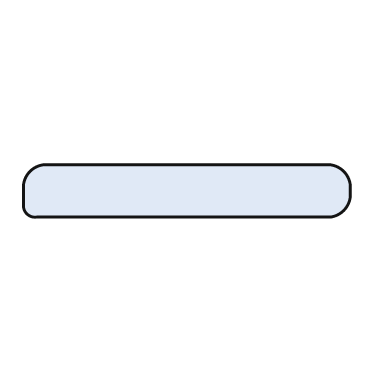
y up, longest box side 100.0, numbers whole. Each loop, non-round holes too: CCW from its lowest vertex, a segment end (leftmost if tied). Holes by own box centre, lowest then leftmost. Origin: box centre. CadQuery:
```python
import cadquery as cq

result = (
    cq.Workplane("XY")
    .moveTo(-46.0, -8.0)
    .lineTo(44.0, -8.0)
    .threePointArc((48.0, -6.0), (50.0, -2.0))
    .lineTo(50.0, 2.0)
    .threePointArc((48.0, 6.0), (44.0, 8.0))
    .lineTo(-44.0, 8.0)
    .threePointArc((-48.0, 6.0), (-50.0, 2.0))
    .lineTo(-50.0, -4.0)
    .threePointArc((-49.0, -7.0), (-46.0, -8.0))
    .close()
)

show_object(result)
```